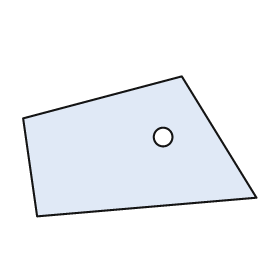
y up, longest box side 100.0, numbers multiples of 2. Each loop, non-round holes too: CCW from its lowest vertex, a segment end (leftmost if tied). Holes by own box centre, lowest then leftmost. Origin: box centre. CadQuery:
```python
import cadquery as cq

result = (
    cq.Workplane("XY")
    .moveTo(-44.0, -30.0)
    .lineTo(50.0, -22.0)
    .lineTo(18.0, 30.0)
    .lineTo(-50.0, 12.0)
    .close()
    .moveTo(10.0, 4.0)
    .circle(4.0)
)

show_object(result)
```